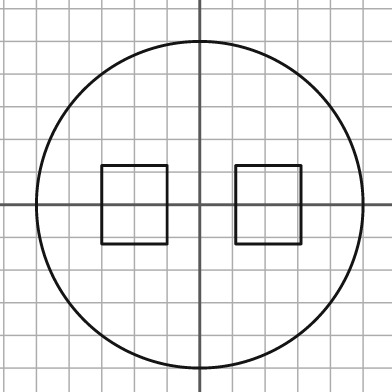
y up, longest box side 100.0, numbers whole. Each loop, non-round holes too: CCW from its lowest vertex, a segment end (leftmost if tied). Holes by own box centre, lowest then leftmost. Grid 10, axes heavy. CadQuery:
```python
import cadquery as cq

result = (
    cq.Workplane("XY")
    .moveTo(0.0, 0.0)
    .circle(50.0)
    .moveTo(-30.0, -12.0)
    .lineTo(-10.0, -12.0)
    .lineTo(-10.0, 12.0)
    .lineTo(-30.0, 12.0)
    .close()
    .moveTo(11.0, -12.0)
    .lineTo(31.0, -12.0)
    .lineTo(31.0, 12.0)
    .lineTo(11.0, 12.0)
    .close()
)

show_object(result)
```